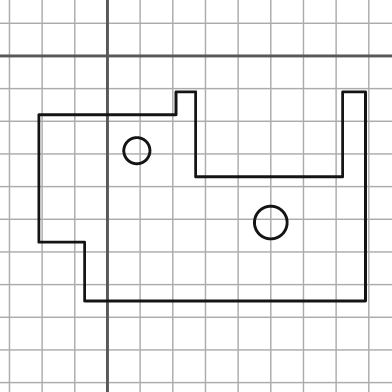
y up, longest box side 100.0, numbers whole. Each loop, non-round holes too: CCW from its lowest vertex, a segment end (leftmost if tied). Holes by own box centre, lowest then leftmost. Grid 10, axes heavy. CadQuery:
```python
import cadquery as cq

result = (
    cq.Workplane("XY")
    .moveTo(-7.0, -75.0)
    .lineTo(79.0, -75.0)
    .lineTo(79.0, -11.0)
    .lineTo(72.0, -11.0)
    .lineTo(72.0, -37.0)
    .lineTo(27.0, -37.0)
    .lineTo(27.0, -11.0)
    .lineTo(21.0, -11.0)
    .lineTo(21.0, -18.0)
    .lineTo(-21.0, -18.0)
    .lineTo(-21.0, -57.0)
    .lineTo(-7.0, -57.0)
    .close()
    .moveTo(50.0, -51.0)
    .circle(5.0)
    .moveTo(9.0, -29.0)
    .circle(4.0)
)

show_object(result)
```